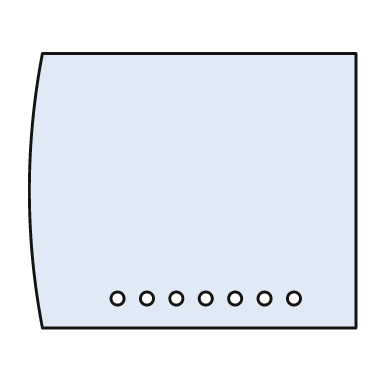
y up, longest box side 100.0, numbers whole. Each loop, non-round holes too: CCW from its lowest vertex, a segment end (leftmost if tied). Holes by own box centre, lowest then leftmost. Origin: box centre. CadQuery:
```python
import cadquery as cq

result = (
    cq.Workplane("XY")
    .moveTo(-46.0, -42.0)
    .lineTo(50.0, -42.0)
    .lineTo(50.0, 42.0)
    .lineTo(-46.0, 42.0)
    .threePointArc((-50.0, 0.0), (-46.0, -42.0))
    .close()
    .moveTo(-23.0, -33.0)
    .circle(2.0)
    .moveTo(-14.0, -33.0)
    .circle(2.0)
    .moveTo(-5.0, -33.0)
    .circle(2.0)
    .moveTo(4.0, -33.0)
    .circle(2.0)
    .moveTo(13.0, -33.0)
    .circle(2.0)
    .moveTo(22.0, -33.0)
    .circle(2.0)
    .moveTo(31.0, -33.0)
    .circle(2.0)
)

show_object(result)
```